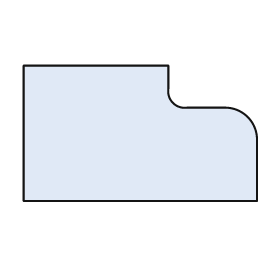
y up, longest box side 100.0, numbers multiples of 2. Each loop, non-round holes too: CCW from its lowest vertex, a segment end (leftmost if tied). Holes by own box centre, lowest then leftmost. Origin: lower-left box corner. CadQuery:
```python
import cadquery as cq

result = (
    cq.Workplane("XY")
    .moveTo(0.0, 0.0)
    .lineTo(100.0, 0.0)
    .lineTo(100.0, 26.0)
    .threePointArc((96.0, 36.0), (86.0, 40.0))
    .lineTo(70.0, 40.0)
    .threePointArc((64.0, 42.0), (62.0, 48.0))
    .lineTo(62.0, 58.0)
    .lineTo(0.0, 58.0)
    .close()
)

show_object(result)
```